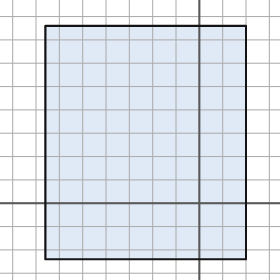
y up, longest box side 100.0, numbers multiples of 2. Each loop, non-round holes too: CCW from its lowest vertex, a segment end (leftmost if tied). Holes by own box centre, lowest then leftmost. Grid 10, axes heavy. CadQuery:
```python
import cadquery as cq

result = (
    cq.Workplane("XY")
    .moveTo(-66.0, -24.0)
    .lineTo(20.0, -24.0)
    .lineTo(20.0, 76.0)
    .lineTo(-66.0, 76.0)
    .close()
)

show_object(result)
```